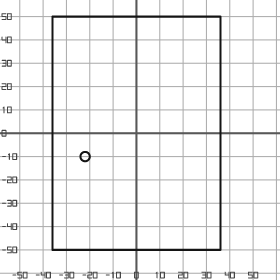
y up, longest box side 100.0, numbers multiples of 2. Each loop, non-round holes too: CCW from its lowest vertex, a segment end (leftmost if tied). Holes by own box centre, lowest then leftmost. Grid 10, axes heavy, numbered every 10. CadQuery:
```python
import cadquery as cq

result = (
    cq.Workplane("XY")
    .moveTo(-36.0, -50.0)
    .lineTo(36.0, -50.0)
    .lineTo(36.0, 50.0)
    .lineTo(-36.0, 50.0)
    .close()
    .moveTo(-22.0, -10.0)
    .circle(2.0)
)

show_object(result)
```